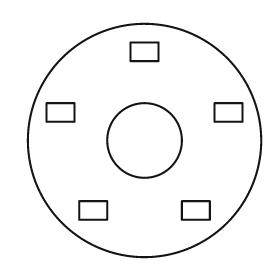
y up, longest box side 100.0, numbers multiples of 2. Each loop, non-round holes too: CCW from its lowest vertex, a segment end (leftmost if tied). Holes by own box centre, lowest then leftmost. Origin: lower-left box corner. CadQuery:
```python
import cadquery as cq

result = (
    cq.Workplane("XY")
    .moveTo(50.0, 50.0)
    .circle(50.0)
    .moveTo(22.0, 16.0)
    .lineTo(34.0, 16.0)
    .lineTo(34.0, 24.0)
    .lineTo(22.0, 24.0)
    .close()
    .moveTo(66.0, 16.0)
    .lineTo(78.0, 16.0)
    .lineTo(78.0, 24.0)
    .lineTo(66.0, 24.0)
    .close()
    .moveTo(50.0, 50.0)
    .circle(16.0)
    .moveTo(8.0, 58.0)
    .lineTo(20.0, 58.0)
    .lineTo(20.0, 66.0)
    .lineTo(8.0, 66.0)
    .close()
    .moveTo(80.0, 58.0)
    .lineTo(92.0, 58.0)
    .lineTo(92.0, 66.0)
    .lineTo(80.0, 66.0)
    .close()
    .moveTo(44.0, 84.0)
    .lineTo(56.0, 84.0)
    .lineTo(56.0, 92.0)
    .lineTo(44.0, 92.0)
    .close()
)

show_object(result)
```